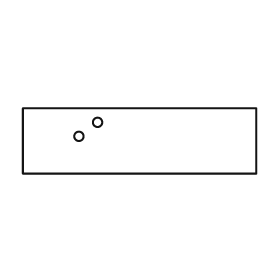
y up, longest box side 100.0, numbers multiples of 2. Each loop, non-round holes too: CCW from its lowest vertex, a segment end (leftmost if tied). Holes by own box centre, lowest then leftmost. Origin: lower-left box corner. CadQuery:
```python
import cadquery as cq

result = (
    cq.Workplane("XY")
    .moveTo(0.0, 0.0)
    .lineTo(100.0, 0.0)
    .lineTo(100.0, 28.0)
    .lineTo(0.0, 28.0)
    .close()
    .moveTo(24.0, 16.0)
    .circle(2.0)
    .moveTo(32.0, 22.0)
    .circle(2.0)
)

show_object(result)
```